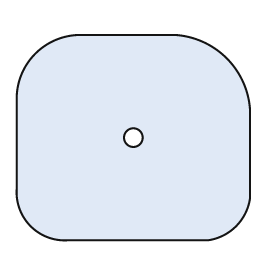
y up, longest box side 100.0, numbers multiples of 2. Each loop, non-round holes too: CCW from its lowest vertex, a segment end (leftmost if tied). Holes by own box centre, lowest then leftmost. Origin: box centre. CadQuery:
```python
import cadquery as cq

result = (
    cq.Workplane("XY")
    .moveTo(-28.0, -44.0)
    .lineTo(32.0, -44.0)
    .threePointArc((44.0, -38.0), (50.0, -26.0))
    .lineTo(50.0, 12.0)
    .threePointArc((40.0, 34.0), (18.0, 44.0))
    .lineTo(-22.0, 44.0)
    .threePointArc((-42.0, 36.0), (-50.0, 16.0))
    .lineTo(-50.0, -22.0)
    .threePointArc((-44.0, -38.0), (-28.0, -44.0))
    .close()
    .moveTo(0.0, 0.0)
    .circle(4.0)
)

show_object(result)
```